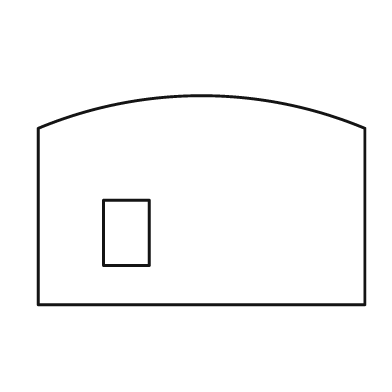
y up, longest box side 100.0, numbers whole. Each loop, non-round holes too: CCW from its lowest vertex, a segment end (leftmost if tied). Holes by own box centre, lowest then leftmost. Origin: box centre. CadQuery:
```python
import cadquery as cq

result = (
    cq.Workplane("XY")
    .moveTo(-50.0, -32.0)
    .lineTo(50.0, -32.0)
    .lineTo(50.0, 22.0)
    .threePointArc((0.0, 32.0), (-50.0, 22.0))
    .close()
    .moveTo(-30.0, -20.0)
    .lineTo(-16.0, -20.0)
    .lineTo(-16.0, 0.0)
    .lineTo(-30.0, 0.0)
    .close()
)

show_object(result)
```